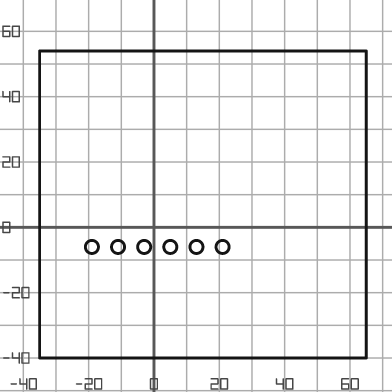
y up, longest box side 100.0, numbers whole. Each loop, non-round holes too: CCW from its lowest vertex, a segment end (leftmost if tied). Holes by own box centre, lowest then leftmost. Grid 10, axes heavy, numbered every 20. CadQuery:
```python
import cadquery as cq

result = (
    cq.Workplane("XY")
    .moveTo(-35.0, -40.0)
    .lineTo(65.0, -40.0)
    .lineTo(65.0, 54.0)
    .lineTo(-35.0, 54.0)
    .close()
    .moveTo(-19.0, -6.0)
    .circle(2.0)
    .moveTo(-11.0, -6.0)
    .circle(2.0)
    .moveTo(-3.0, -6.0)
    .circle(2.0)
    .moveTo(5.0, -6.0)
    .circle(2.0)
    .moveTo(13.0, -6.0)
    .circle(2.0)
    .moveTo(21.0, -6.0)
    .circle(2.0)
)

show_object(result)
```